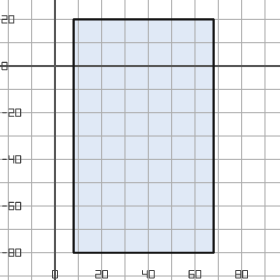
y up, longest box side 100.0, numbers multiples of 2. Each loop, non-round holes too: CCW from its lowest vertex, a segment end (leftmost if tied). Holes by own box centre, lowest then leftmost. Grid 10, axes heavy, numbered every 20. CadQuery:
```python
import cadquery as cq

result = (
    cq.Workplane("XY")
    .moveTo(8.0, -80.0)
    .lineTo(68.0, -80.0)
    .lineTo(68.0, 20.0)
    .lineTo(8.0, 20.0)
    .close()
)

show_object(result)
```